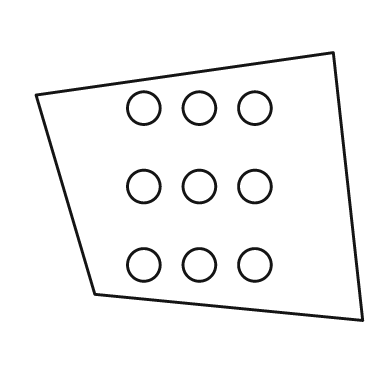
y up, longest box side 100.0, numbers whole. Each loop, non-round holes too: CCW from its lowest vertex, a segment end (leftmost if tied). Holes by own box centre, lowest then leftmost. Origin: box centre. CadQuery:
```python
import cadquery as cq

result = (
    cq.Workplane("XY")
    .moveTo(50.0, -41.0)
    .lineTo(41.0, 41.0)
    .lineTo(-50.0, 28.0)
    .lineTo(-32.0, -33.0)
    .close()
    .moveTo(-17.0, -24.0)
    .circle(5.0)
    .moveTo(0.0, -24.0)
    .circle(5.0)
    .moveTo(17.0, -24.0)
    .circle(5.0)
    .moveTo(-17.0, 0.0)
    .circle(5.0)
    .moveTo(0.0, 0.0)
    .circle(5.0)
    .moveTo(17.0, 0.0)
    .circle(5.0)
    .moveTo(-17.0, 24.0)
    .circle(5.0)
    .moveTo(0.0, 24.0)
    .circle(5.0)
    .moveTo(17.0, 24.0)
    .circle(5.0)
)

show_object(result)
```